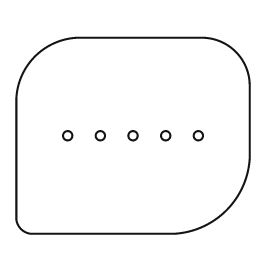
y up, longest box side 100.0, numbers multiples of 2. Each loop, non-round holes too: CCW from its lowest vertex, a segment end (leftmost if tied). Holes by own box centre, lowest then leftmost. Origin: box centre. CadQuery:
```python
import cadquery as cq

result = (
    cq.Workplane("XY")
    .moveTo(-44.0, -42.0)
    .lineTo(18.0, -42.0)
    .threePointArc((40.0, -32.0), (50.0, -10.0))
    .lineTo(50.0, 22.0)
    .threePointArc((44.0, 36.0), (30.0, 42.0))
    .lineTo(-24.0, 42.0)
    .threePointArc((-42.0, 34.0), (-50.0, 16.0))
    .lineTo(-50.0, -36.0)
    .threePointArc((-48.0, -40.0), (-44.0, -42.0))
    .close()
    .moveTo(-28.0, 0.0)
    .circle(2.0)
    .moveTo(-14.0, 0.0)
    .circle(2.0)
    .moveTo(0.0, 0.0)
    .circle(2.0)
    .moveTo(14.0, 0.0)
    .circle(2.0)
    .moveTo(28.0, 0.0)
    .circle(2.0)
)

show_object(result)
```